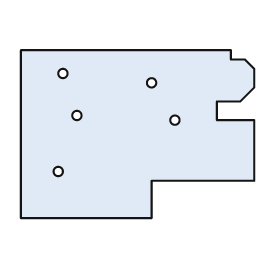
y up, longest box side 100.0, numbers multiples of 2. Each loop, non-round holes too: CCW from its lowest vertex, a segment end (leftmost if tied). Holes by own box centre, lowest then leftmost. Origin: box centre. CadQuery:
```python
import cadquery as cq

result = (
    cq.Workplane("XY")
    .moveTo(-50.0, -36.0)
    .lineTo(6.0, -36.0)
    .lineTo(6.0, -20.0)
    .lineTo(50.0, -20.0)
    .lineTo(50.0, 6.0)
    .lineTo(34.0, 6.0)
    .lineTo(34.0, 14.0)
    .lineTo(44.0, 14.0)
    .lineTo(50.0, 20.0)
    .lineTo(50.0, 28.0)
    .lineTo(46.0, 32.0)
    .lineTo(40.0, 32.0)
    .lineTo(40.0, 36.0)
    .lineTo(-50.0, 36.0)
    .close()
    .moveTo(-34.0, -16.0)
    .circle(2.0)
    .moveTo(16.0, 6.0)
    .circle(2.0)
    .moveTo(-26.0, 8.0)
    .circle(2.0)
    .moveTo(6.0, 22.0)
    .circle(2.0)
    .moveTo(-32.0, 26.0)
    .circle(2.0)
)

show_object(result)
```